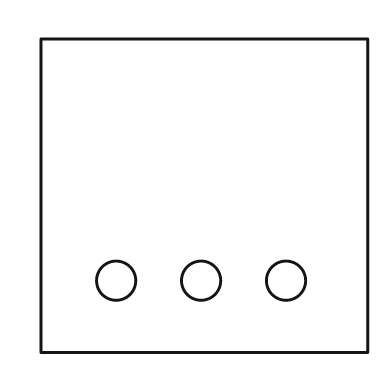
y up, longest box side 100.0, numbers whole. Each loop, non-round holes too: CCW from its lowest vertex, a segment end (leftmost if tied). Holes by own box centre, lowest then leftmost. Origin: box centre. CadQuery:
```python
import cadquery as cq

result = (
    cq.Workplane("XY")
    .moveTo(-50.0, -48.0)
    .lineTo(50.0, -48.0)
    .lineTo(50.0, 48.0)
    .lineTo(-50.0, 48.0)
    .close()
    .moveTo(-27.0, -26.0)
    .circle(6.0)
    .moveTo(-1.0, -26.0)
    .circle(6.0)
    .moveTo(25.0, -26.0)
    .circle(6.0)
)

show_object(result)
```